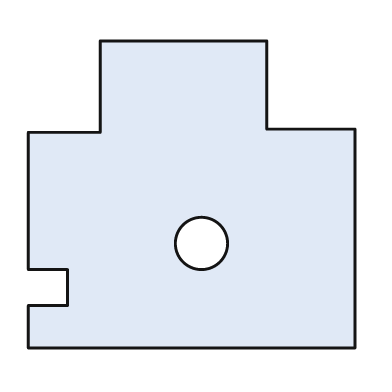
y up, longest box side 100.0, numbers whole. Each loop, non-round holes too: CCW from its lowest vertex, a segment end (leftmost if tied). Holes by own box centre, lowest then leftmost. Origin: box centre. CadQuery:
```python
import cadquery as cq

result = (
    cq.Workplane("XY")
    .moveTo(-50.0, -47.0)
    .lineTo(50.0, -47.0)
    .lineTo(50.0, 20.0)
    .lineTo(23.0, 20.0)
    .lineTo(23.0, 47.0)
    .lineTo(-28.0, 47.0)
    .lineTo(-28.0, 19.0)
    .lineTo(-50.0, 19.0)
    .lineTo(-50.0, -23.0)
    .lineTo(-38.0, -23.0)
    .lineTo(-38.0, -34.0)
    .lineTo(-50.0, -34.0)
    .close()
    .moveTo(3.0, -15.0)
    .circle(8.0)
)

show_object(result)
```